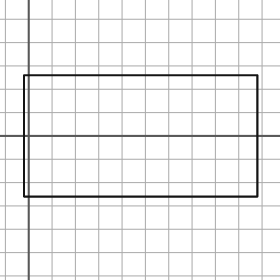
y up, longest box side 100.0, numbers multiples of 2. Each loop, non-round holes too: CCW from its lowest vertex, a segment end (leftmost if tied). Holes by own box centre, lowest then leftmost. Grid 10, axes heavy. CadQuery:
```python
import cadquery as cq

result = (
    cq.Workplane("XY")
    .moveTo(-2.0, -26.0)
    .lineTo(98.0, -26.0)
    .lineTo(98.0, 26.0)
    .lineTo(-2.0, 26.0)
    .close()
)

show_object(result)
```